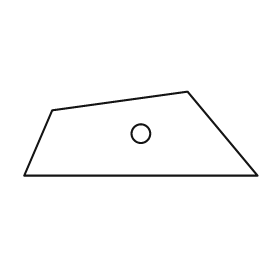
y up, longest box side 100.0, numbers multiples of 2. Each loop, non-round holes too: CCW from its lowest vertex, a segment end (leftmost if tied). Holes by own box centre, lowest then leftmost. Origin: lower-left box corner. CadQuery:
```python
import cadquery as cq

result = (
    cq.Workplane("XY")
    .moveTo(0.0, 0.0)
    .lineTo(100.0, 0.0)
    .lineTo(70.0, 36.0)
    .lineTo(12.0, 28.0)
    .close()
    .moveTo(50.0, 18.0)
    .circle(4.0)
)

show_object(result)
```